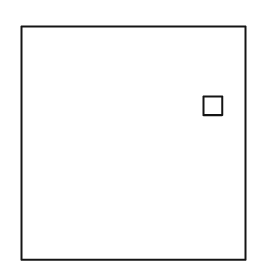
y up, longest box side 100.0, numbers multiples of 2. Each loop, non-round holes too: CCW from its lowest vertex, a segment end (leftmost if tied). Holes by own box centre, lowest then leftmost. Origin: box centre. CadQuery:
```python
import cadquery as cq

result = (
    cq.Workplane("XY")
    .moveTo(-48.0, -50.0)
    .lineTo(48.0, -50.0)
    .lineTo(48.0, 50.0)
    .lineTo(-48.0, 50.0)
    .close()
    .moveTo(30.0, 12.0)
    .lineTo(38.0, 12.0)
    .lineTo(38.0, 20.0)
    .lineTo(30.0, 20.0)
    .close()
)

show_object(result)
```